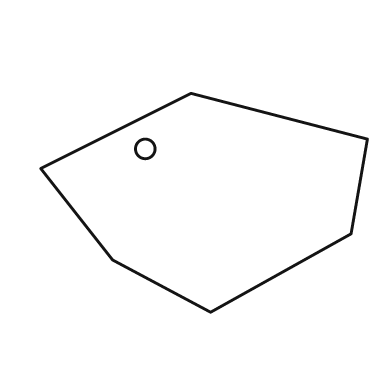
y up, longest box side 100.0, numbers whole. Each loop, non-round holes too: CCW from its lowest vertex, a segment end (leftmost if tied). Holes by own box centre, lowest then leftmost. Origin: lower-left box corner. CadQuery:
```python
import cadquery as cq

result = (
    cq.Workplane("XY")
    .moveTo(52.0, 0.0)
    .lineTo(95.0, 24.0)
    .lineTo(100.0, 53.0)
    .lineTo(46.0, 67.0)
    .lineTo(0.0, 44.0)
    .lineTo(22.0, 16.0)
    .close()
    .moveTo(32.0, 50.0)
    .circle(3.0)
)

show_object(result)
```